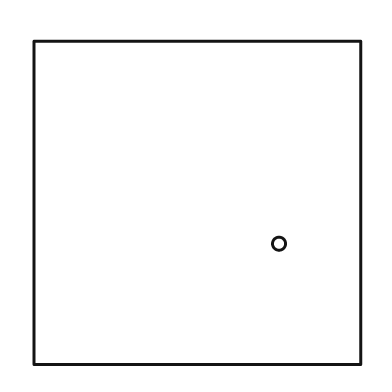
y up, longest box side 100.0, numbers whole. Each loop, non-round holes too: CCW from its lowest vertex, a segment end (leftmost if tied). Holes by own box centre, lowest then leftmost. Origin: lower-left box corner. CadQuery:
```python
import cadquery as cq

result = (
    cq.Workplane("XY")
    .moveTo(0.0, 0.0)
    .lineTo(100.0, 0.0)
    .lineTo(100.0, 99.0)
    .lineTo(0.0, 99.0)
    .close()
    .moveTo(75.0, 37.0)
    .circle(2.0)
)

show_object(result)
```